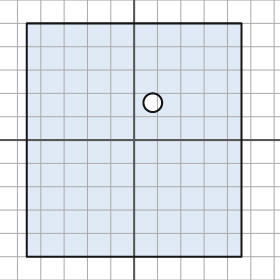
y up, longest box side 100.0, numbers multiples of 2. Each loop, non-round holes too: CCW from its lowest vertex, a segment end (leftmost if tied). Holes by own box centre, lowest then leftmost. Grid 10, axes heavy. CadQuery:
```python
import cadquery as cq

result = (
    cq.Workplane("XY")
    .moveTo(-46.0, -50.0)
    .lineTo(46.0, -50.0)
    .lineTo(46.0, 50.0)
    .lineTo(-46.0, 50.0)
    .close()
    .moveTo(8.0, 16.0)
    .circle(4.0)
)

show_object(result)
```